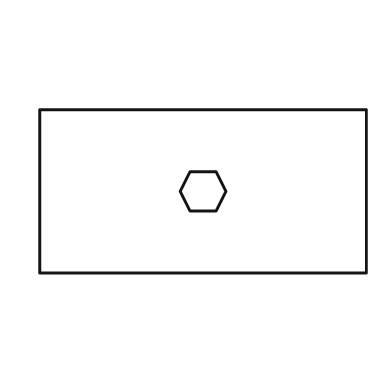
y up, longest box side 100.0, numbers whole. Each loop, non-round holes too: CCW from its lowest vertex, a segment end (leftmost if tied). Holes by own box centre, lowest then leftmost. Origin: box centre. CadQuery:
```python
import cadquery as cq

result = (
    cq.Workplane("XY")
    .moveTo(-50.0, -25.0)
    .lineTo(50.0, -25.0)
    .lineTo(50.0, 25.0)
    .lineTo(-50.0, 25.0)
    .close()
    .moveTo(-4.0, -6.0)
    .lineTo(4.0, -6.0)
    .lineTo(7.0, 0.0)
    .lineTo(4.0, 6.0)
    .lineTo(-4.0, 6.0)
    .lineTo(-7.0, 0.0)
    .close()
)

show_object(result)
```